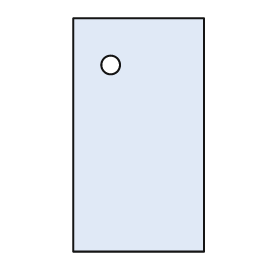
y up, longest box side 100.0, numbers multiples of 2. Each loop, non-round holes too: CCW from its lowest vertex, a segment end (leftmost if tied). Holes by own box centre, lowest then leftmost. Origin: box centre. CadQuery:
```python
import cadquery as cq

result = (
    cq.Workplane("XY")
    .moveTo(-28.0, -50.0)
    .lineTo(28.0, -50.0)
    .lineTo(28.0, 50.0)
    .lineTo(-28.0, 50.0)
    .close()
    .moveTo(-12.0, 30.0)
    .circle(4.0)
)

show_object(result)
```